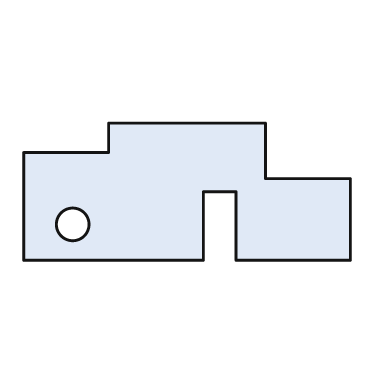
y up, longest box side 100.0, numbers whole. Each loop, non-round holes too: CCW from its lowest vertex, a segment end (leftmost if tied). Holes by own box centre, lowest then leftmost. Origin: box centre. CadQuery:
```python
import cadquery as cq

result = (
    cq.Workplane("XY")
    .moveTo(-50.0, -21.0)
    .lineTo(5.0, -21.0)
    .lineTo(5.0, 0.0)
    .lineTo(15.0, 0.0)
    .lineTo(15.0, -21.0)
    .lineTo(50.0, -21.0)
    .lineTo(50.0, 4.0)
    .lineTo(24.0, 4.0)
    .lineTo(24.0, 21.0)
    .lineTo(-24.0, 21.0)
    .lineTo(-24.0, 12.0)
    .lineTo(-50.0, 12.0)
    .close()
    .moveTo(-35.0, -10.0)
    .circle(5.0)
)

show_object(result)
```